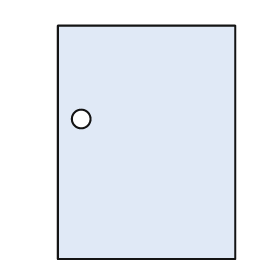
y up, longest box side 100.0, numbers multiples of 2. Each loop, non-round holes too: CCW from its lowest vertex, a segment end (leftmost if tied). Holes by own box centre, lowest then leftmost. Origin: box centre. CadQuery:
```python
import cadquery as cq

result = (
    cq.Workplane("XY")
    .moveTo(-38.0, -50.0)
    .lineTo(38.0, -50.0)
    .lineTo(38.0, 50.0)
    .lineTo(-38.0, 50.0)
    .close()
    .moveTo(-28.0, 10.0)
    .circle(4.0)
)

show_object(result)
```